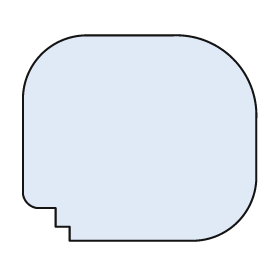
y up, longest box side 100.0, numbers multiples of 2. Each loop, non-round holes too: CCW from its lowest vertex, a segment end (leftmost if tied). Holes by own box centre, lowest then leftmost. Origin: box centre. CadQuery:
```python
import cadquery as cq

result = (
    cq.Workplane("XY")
    .moveTo(-30.0, -44.0)
    .lineTo(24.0, -44.0)
    .threePointArc((42.0, -36.0), (50.0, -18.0))
    .lineTo(50.0, 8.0)
    .threePointArc((40.0, 34.0), (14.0, 44.0))
    .lineTo(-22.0, 44.0)
    .threePointArc((-42.0, 36.0), (-50.0, 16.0))
    .lineTo(-50.0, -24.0)
    .threePointArc((-48.0, -28.0), (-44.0, -30.0))
    .lineTo(-36.0, -30.0)
    .lineTo(-36.0, -38.0)
    .lineTo(-30.0, -38.0)
    .close()
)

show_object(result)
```